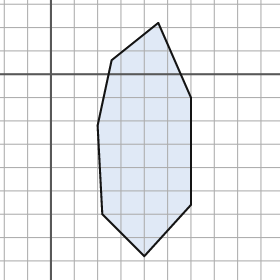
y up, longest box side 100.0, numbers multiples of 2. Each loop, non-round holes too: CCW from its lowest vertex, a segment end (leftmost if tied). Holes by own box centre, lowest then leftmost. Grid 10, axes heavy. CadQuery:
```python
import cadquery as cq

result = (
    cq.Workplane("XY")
    .moveTo(40.0, -78.0)
    .lineTo(60.0, -56.0)
    .lineTo(60.0, -10.0)
    .lineTo(46.0, 22.0)
    .lineTo(26.0, 6.0)
    .lineTo(20.0, -22.0)
    .lineTo(22.0, -60.0)
    .close()
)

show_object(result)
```